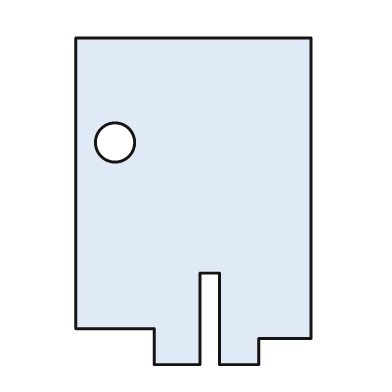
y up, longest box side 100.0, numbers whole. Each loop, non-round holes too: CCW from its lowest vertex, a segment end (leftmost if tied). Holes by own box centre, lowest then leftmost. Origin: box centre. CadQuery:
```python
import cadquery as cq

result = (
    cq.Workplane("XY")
    .moveTo(-12.0, -50.0)
    .lineTo(2.0, -50.0)
    .lineTo(2.0, -22.0)
    .lineTo(8.0, -22.0)
    .lineTo(8.0, -50.0)
    .lineTo(20.0, -50.0)
    .lineTo(20.0, -42.0)
    .lineTo(36.0, -42.0)
    .lineTo(36.0, 50.0)
    .lineTo(-36.0, 50.0)
    .lineTo(-36.0, -39.0)
    .lineTo(-12.0, -39.0)
    .close()
    .moveTo(-24.0, 18.0)
    .circle(6.0)
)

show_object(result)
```